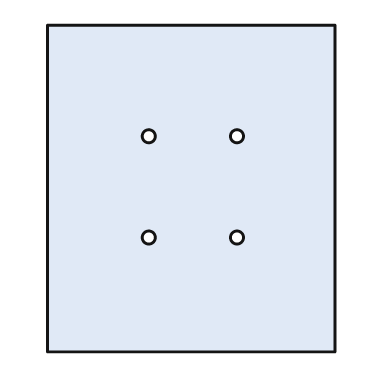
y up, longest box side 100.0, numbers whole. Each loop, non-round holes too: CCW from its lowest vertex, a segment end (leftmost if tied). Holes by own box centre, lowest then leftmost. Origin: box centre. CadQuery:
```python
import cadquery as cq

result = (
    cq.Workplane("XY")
    .moveTo(-44.0, -50.0)
    .lineTo(44.0, -50.0)
    .lineTo(44.0, 50.0)
    .lineTo(-44.0, 50.0)
    .close()
    .moveTo(-13.0, -15.0)
    .circle(2.0)
    .moveTo(14.0, -15.0)
    .circle(2.0)
    .moveTo(-13.0, 16.0)
    .circle(2.0)
    .moveTo(14.0, 16.0)
    .circle(2.0)
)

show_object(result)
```